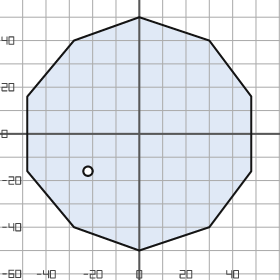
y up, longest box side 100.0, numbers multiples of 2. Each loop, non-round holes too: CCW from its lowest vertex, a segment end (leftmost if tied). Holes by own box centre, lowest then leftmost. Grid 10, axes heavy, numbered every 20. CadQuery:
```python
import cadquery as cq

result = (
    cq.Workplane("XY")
    .moveTo(0.0, -50.0)
    .lineTo(30.0, -40.0)
    .lineTo(48.0, -16.0)
    .lineTo(48.0, 16.0)
    .lineTo(30.0, 40.0)
    .lineTo(0.0, 50.0)
    .lineTo(-28.0, 40.0)
    .lineTo(-48.0, 16.0)
    .lineTo(-48.0, -16.0)
    .lineTo(-28.0, -40.0)
    .close()
    .moveTo(-22.0, -16.0)
    .circle(2.0)
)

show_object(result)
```